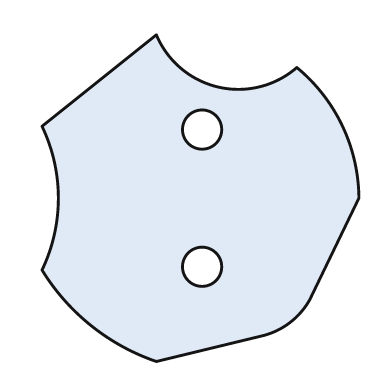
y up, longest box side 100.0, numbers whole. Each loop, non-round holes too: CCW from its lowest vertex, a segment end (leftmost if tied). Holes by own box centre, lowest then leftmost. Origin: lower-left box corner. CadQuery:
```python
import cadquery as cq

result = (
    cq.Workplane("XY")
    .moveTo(35.0, 0.0)
    .lineTo(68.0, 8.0)
    .threePointArc((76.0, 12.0), (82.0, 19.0))
    .lineTo(97.0, 50.0)
    .threePointArc((92.0, 72.0), (78.0, 90.0))
    .threePointArc((54.0, 84.0), (35.0, 100.0))
    .lineTo(0.0, 72.0)
    .threePointArc((5.0, 50.0), (0.0, 28.0))
    .threePointArc((15.0, 11.0), (35.0, 0.0))
    .close()
    .moveTo(49.0, 29.0)
    .circle(6.0)
    .moveTo(49.0, 71.0)
    .circle(6.0)
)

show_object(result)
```